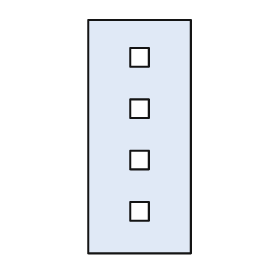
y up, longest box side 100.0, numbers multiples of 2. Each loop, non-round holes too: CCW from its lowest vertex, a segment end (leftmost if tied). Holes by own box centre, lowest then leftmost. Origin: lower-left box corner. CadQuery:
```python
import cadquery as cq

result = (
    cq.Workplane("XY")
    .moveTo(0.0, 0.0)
    .lineTo(44.0, 0.0)
    .lineTo(44.0, 100.0)
    .lineTo(0.0, 100.0)
    .close()
    .moveTo(18.0, 14.0)
    .lineTo(26.0, 14.0)
    .lineTo(26.0, 22.0)
    .lineTo(18.0, 22.0)
    .close()
    .moveTo(18.0, 36.0)
    .lineTo(26.0, 36.0)
    .lineTo(26.0, 44.0)
    .lineTo(18.0, 44.0)
    .close()
    .moveTo(18.0, 58.0)
    .lineTo(26.0, 58.0)
    .lineTo(26.0, 66.0)
    .lineTo(18.0, 66.0)
    .close()
    .moveTo(18.0, 80.0)
    .lineTo(26.0, 80.0)
    .lineTo(26.0, 88.0)
    .lineTo(18.0, 88.0)
    .close()
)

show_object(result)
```